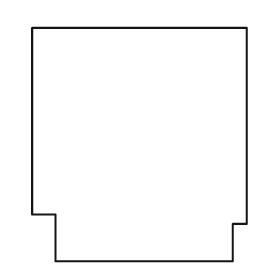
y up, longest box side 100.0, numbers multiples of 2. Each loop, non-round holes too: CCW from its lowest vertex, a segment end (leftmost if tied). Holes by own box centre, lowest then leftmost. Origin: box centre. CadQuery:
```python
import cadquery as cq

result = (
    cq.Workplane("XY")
    .moveTo(-36.0, -50.0)
    .lineTo(40.0, -50.0)
    .lineTo(40.0, -34.0)
    .lineTo(46.0, -34.0)
    .lineTo(46.0, 50.0)
    .lineTo(-46.0, 50.0)
    .lineTo(-46.0, -30.0)
    .lineTo(-36.0, -30.0)
    .close()
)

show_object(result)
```